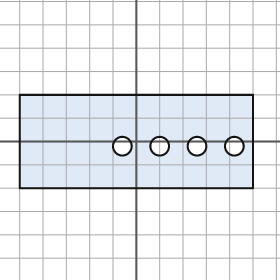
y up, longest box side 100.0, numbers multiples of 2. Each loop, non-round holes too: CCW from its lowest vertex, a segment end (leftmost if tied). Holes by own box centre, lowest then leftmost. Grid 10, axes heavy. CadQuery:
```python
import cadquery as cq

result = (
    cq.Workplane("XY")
    .moveTo(-50.0, -20.0)
    .lineTo(50.0, -20.0)
    .lineTo(50.0, 20.0)
    .lineTo(-50.0, 20.0)
    .close()
    .moveTo(-6.0, -2.0)
    .circle(4.0)
    .moveTo(10.0, -2.0)
    .circle(4.0)
    .moveTo(26.0, -2.0)
    .circle(4.0)
    .moveTo(42.0, -2.0)
    .circle(4.0)
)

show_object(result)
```